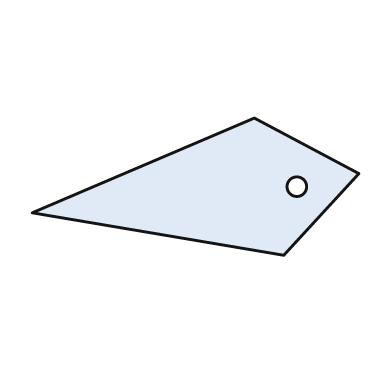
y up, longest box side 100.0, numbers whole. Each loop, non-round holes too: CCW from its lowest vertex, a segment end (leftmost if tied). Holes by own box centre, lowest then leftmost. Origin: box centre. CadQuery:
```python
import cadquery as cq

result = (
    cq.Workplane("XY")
    .moveTo(27.0, -21.0)
    .lineTo(50.0, 4.0)
    .lineTo(18.0, 21.0)
    .lineTo(-50.0, -8.0)
    .close()
    .moveTo(31.0, 0.0)
    .circle(3.0)
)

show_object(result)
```